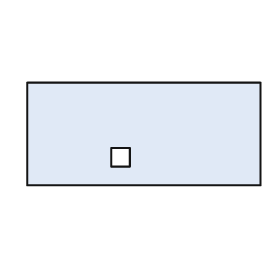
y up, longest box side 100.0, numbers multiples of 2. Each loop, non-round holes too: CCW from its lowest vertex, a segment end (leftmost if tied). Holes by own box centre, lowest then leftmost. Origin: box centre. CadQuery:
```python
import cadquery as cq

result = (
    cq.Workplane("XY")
    .moveTo(-50.0, -22.0)
    .lineTo(50.0, -22.0)
    .lineTo(50.0, 22.0)
    .lineTo(-50.0, 22.0)
    .close()
    .moveTo(-14.0, -14.0)
    .lineTo(-6.0, -14.0)
    .lineTo(-6.0, -6.0)
    .lineTo(-14.0, -6.0)
    .close()
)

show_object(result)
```